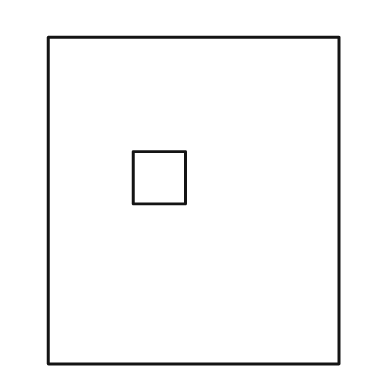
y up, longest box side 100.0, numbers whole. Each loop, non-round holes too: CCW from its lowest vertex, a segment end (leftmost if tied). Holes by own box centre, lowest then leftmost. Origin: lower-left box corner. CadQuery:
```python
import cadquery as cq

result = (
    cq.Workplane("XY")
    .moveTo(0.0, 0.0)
    .lineTo(89.0, 0.0)
    .lineTo(89.0, 100.0)
    .lineTo(0.0, 100.0)
    .close()
    .moveTo(26.0, 49.0)
    .lineTo(42.0, 49.0)
    .lineTo(42.0, 65.0)
    .lineTo(26.0, 65.0)
    .close()
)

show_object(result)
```